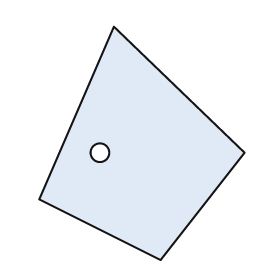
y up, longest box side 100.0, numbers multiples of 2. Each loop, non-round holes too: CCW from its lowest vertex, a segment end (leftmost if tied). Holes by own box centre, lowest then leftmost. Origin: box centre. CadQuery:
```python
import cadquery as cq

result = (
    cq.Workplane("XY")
    .moveTo(8.0, -50.0)
    .lineTo(44.0, -4.0)
    .lineTo(-12.0, 50.0)
    .lineTo(-44.0, -24.0)
    .close()
    .moveTo(-18.0, -4.0)
    .circle(4.0)
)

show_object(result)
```